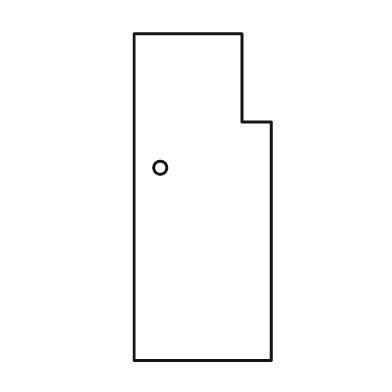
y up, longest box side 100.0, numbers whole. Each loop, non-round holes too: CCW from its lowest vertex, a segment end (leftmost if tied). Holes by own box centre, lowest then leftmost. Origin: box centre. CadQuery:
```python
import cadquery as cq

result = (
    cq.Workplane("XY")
    .moveTo(-21.0, -50.0)
    .lineTo(21.0, -50.0)
    .lineTo(21.0, 23.0)
    .lineTo(12.0, 23.0)
    .lineTo(12.0, 50.0)
    .lineTo(-21.0, 50.0)
    .close()
    .moveTo(-13.0, 9.0)
    .circle(2.0)
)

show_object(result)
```